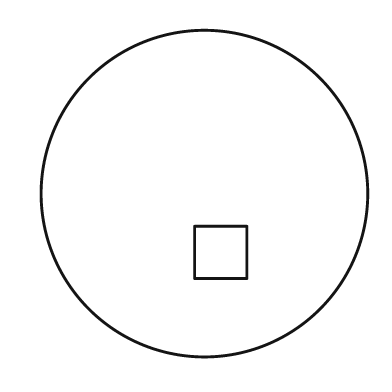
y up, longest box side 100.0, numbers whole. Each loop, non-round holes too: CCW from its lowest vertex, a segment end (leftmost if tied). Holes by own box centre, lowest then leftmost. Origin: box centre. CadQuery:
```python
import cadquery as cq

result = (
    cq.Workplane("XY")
    .moveTo(0.0, 0.0)
    .circle(50.0)
    .moveTo(-3.0, -26.0)
    .lineTo(13.0, -26.0)
    .lineTo(13.0, -10.0)
    .lineTo(-3.0, -10.0)
    .close()
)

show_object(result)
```